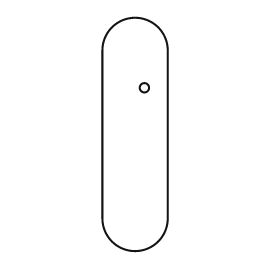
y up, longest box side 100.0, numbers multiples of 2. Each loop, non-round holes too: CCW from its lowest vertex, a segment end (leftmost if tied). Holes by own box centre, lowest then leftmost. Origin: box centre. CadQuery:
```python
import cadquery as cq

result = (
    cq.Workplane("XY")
    .moveTo(-14.0, -36.0)
    .threePointArc((0.0, -50.0), (14.0, -36.0))
    .lineTo(14.0, 36.0)
    .threePointArc((0.0, 50.0), (-14.0, 36.0))
    .close()
    .moveTo(4.0, 20.0)
    .circle(2.0)
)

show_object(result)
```